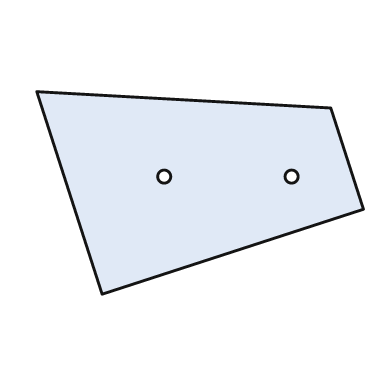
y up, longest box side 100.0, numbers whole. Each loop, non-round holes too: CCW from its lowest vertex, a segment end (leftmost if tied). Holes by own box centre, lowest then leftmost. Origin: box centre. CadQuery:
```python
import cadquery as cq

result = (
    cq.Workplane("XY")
    .moveTo(-30.0, -31.0)
    .lineTo(50.0, -5.0)
    .lineTo(40.0, 26.0)
    .lineTo(-50.0, 31.0)
    .close()
    .moveTo(-11.0, 5.0)
    .circle(2.0)
    .moveTo(28.0, 5.0)
    .circle(2.0)
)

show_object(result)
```